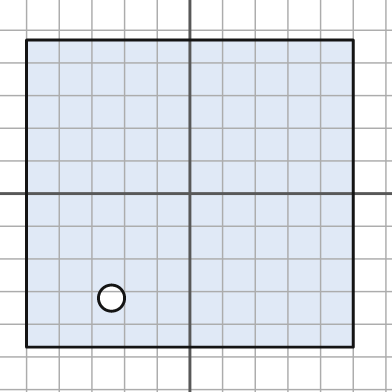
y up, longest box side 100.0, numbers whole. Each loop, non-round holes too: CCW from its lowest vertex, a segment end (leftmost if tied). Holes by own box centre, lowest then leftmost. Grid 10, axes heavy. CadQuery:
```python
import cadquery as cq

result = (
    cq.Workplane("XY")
    .moveTo(-50.0, -47.0)
    .lineTo(50.0, -47.0)
    .lineTo(50.0, 47.0)
    .lineTo(-50.0, 47.0)
    .close()
    .moveTo(-24.0, -32.0)
    .circle(4.0)
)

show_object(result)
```